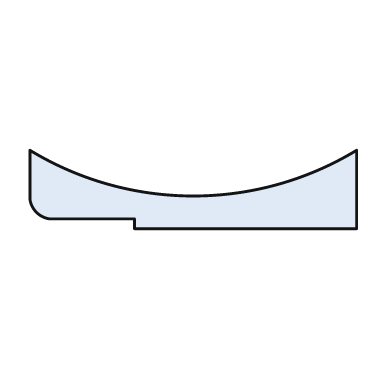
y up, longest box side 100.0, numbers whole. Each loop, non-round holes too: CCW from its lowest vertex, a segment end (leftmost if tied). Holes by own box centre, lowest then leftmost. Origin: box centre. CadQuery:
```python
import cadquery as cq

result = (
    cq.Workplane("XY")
    .moveTo(-18.0, -12.0)
    .lineTo(50.0, -12.0)
    .lineTo(50.0, 12.0)
    .threePointArc((0.0, -2.0), (-50.0, 12.0))
    .lineTo(-50.0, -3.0)
    .threePointArc((-48.0, -7.0), (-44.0, -9.0))
    .lineTo(-18.0, -9.0)
    .close()
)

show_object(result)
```